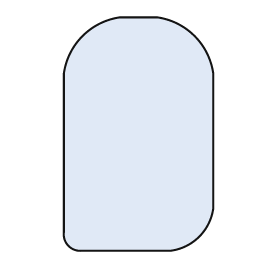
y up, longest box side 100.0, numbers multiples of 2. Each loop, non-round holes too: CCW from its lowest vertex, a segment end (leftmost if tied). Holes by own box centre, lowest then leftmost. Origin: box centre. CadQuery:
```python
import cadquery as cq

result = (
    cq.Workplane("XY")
    .moveTo(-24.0, -50.0)
    .lineTo(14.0, -50.0)
    .threePointArc((26.0, -44.0), (32.0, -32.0))
    .lineTo(32.0, 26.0)
    .threePointArc((24.0, 42.0), (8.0, 50.0))
    .lineTo(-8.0, 50.0)
    .threePointArc((-24.0, 42.0), (-32.0, 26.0))
    .lineTo(-32.0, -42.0)
    .threePointArc((-30.0, -48.0), (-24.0, -50.0))
    .close()
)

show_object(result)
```